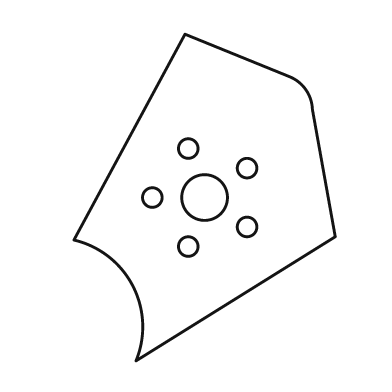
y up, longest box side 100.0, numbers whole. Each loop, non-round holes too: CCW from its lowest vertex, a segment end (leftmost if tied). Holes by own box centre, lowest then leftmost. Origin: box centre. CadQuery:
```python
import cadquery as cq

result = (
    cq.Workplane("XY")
    .moveTo(-21.0, -50.0)
    .lineTo(40.0, -12.0)
    .lineTo(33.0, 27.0)
    .threePointArc((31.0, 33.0), (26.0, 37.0))
    .lineTo(-6.0, 50.0)
    .lineTo(-40.0, -13.0)
    .threePointArc((-22.0, -27.0), (-21.0, -50.0))
    .close()
    .moveTo(-5.0, -15.0)
    .circle(3.0)
    .moveTo(13.0, -9.0)
    .circle(3.0)
    .moveTo(-16.0, 0.0)
    .circle(3.0)
    .moveTo(0.0, 0.0)
    .circle(7.0)
    .moveTo(13.0, 9.0)
    .circle(3.0)
    .moveTo(-5.0, 15.0)
    .circle(3.0)
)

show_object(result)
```